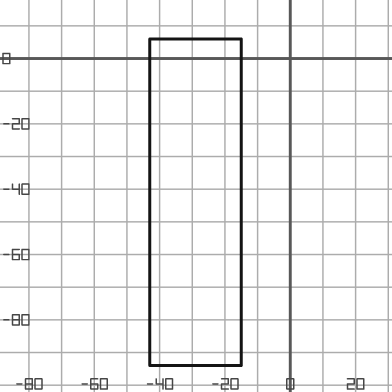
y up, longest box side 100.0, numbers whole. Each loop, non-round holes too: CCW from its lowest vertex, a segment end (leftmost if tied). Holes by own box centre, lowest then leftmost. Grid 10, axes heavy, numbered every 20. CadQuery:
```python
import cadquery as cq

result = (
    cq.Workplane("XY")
    .moveTo(-43.0, -94.0)
    .lineTo(-15.0, -94.0)
    .lineTo(-15.0, 6.0)
    .lineTo(-43.0, 6.0)
    .close()
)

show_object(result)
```